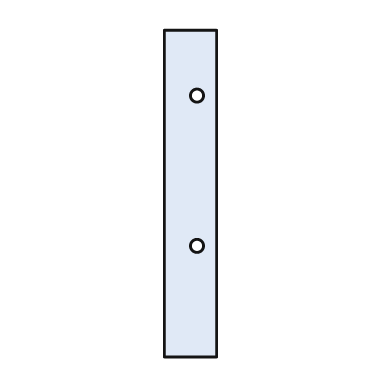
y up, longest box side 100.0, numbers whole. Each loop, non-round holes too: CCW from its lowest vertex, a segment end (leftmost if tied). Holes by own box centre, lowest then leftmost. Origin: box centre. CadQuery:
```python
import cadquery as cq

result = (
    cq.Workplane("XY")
    .moveTo(-8.0, -50.0)
    .lineTo(8.0, -50.0)
    .lineTo(8.0, 50.0)
    .lineTo(-8.0, 50.0)
    .close()
    .moveTo(2.0, -16.0)
    .circle(2.0)
    .moveTo(2.0, 30.0)
    .circle(2.0)
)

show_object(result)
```